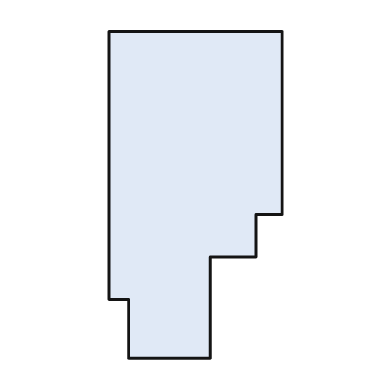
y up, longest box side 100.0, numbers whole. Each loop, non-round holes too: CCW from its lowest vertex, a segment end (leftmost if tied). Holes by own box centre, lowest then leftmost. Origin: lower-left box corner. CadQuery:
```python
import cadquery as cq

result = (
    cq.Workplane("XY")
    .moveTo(6.0, 0.0)
    .lineTo(31.0, 0.0)
    .lineTo(31.0, 31.0)
    .lineTo(45.0, 31.0)
    .lineTo(45.0, 44.0)
    .lineTo(53.0, 44.0)
    .lineTo(53.0, 100.0)
    .lineTo(0.0, 100.0)
    .lineTo(0.0, 18.0)
    .lineTo(6.0, 18.0)
    .close()
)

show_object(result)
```